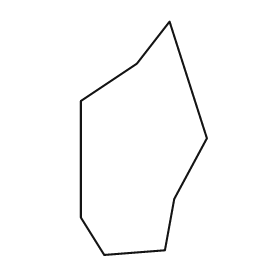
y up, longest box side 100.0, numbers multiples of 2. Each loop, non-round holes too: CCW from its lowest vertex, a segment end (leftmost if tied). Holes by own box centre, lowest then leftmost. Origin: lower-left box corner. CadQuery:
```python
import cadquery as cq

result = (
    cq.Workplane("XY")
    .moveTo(10.0, 0.0)
    .lineTo(36.0, 2.0)
    .lineTo(40.0, 24.0)
    .lineTo(54.0, 50.0)
    .lineTo(38.0, 100.0)
    .lineTo(24.0, 82.0)
    .lineTo(0.0, 66.0)
    .lineTo(0.0, 16.0)
    .close()
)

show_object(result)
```